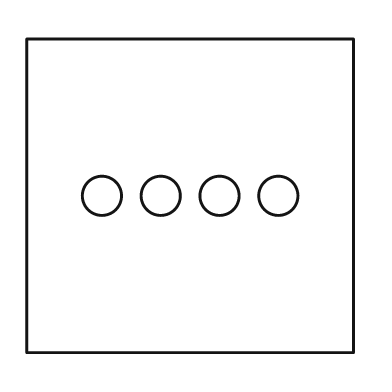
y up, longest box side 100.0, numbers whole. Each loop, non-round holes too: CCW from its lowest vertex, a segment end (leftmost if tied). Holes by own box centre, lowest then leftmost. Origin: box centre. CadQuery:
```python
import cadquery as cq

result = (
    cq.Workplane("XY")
    .moveTo(-50.0, -48.0)
    .lineTo(50.0, -48.0)
    .lineTo(50.0, 48.0)
    .lineTo(-50.0, 48.0)
    .close()
    .moveTo(-27.0, 0.0)
    .circle(6.0)
    .moveTo(-9.0, 0.0)
    .circle(6.0)
    .moveTo(9.0, 0.0)
    .circle(6.0)
    .moveTo(27.0, 0.0)
    .circle(6.0)
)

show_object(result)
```